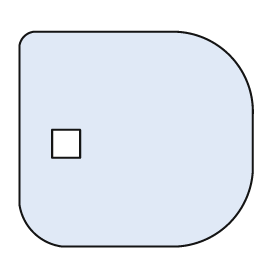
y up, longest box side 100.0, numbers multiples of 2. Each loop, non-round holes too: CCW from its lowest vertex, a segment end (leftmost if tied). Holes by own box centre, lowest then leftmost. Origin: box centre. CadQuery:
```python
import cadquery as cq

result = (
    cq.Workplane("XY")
    .moveTo(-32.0, -46.0)
    .lineTo(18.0, -46.0)
    .threePointArc((40.0, -36.0), (50.0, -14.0))
    .lineTo(50.0, 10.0)
    .threePointArc((40.0, 36.0), (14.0, 46.0))
    .lineTo(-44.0, 46.0)
    .threePointArc((-48.0, 44.0), (-50.0, 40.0))
    .lineTo(-50.0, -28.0)
    .threePointArc((-44.0, -40.0), (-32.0, -46.0))
    .close()
    .moveTo(-36.0, -8.0)
    .lineTo(-24.0, -8.0)
    .lineTo(-24.0, 4.0)
    .lineTo(-36.0, 4.0)
    .close()
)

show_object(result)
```